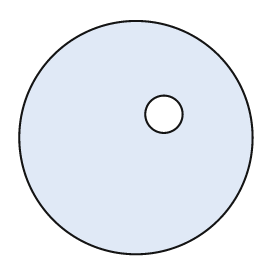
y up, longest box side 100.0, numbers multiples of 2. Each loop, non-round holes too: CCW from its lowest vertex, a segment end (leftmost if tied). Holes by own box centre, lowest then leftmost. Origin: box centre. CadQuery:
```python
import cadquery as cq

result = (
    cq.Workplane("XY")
    .moveTo(0.0, 0.0)
    .circle(50.0)
    .moveTo(12.0, 10.0)
    .circle(8.0)
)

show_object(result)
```